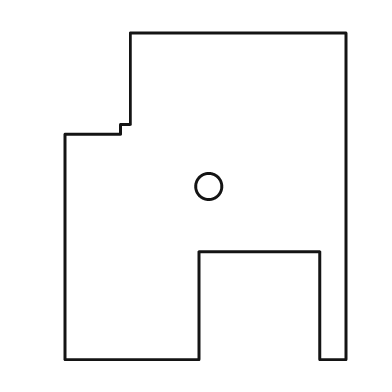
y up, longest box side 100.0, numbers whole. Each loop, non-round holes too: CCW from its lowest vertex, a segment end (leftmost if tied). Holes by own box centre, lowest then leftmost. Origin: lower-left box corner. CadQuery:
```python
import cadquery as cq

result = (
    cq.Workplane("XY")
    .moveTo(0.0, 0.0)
    .lineTo(41.0, 0.0)
    .lineTo(41.0, 33.0)
    .lineTo(78.0, 33.0)
    .lineTo(78.0, 0.0)
    .lineTo(86.0, 0.0)
    .lineTo(86.0, 100.0)
    .lineTo(20.0, 100.0)
    .lineTo(20.0, 72.0)
    .lineTo(17.0, 72.0)
    .lineTo(17.0, 69.0)
    .lineTo(0.0, 69.0)
    .close()
    .moveTo(44.0, 53.0)
    .circle(4.0)
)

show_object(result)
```